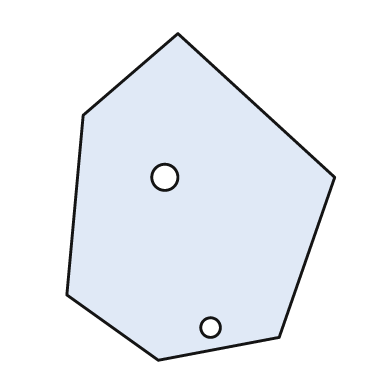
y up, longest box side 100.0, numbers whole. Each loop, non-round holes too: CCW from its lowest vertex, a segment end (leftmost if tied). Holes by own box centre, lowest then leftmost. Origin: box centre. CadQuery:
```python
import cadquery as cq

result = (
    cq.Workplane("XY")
    .moveTo(-13.0, -50.0)
    .lineTo(24.0, -43.0)
    .lineTo(41.0, 6.0)
    .lineTo(-7.0, 50.0)
    .lineTo(-36.0, 25.0)
    .lineTo(-41.0, -30.0)
    .close()
    .moveTo(3.0, -40.0)
    .circle(3.0)
    .moveTo(-11.0, 6.0)
    .circle(4.0)
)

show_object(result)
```